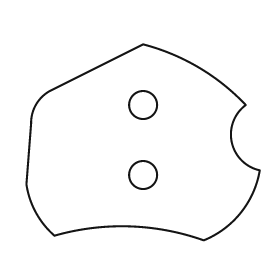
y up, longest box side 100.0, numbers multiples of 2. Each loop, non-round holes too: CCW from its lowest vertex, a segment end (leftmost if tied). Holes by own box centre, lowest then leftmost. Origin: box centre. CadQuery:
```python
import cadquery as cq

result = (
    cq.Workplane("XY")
    .moveTo(26.0, -42.0)
    .threePointArc((42.0, -30.0), (50.0, -12.0))
    .threePointArc((38.0, 0.0), (44.0, 16.0))
    .threePointArc((24.0, 32.0), (0.0, 42.0))
    .lineTo(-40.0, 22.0)
    .threePointArc((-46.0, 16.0), (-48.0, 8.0))
    .lineTo(-50.0, -18.0)
    .threePointArc((-46.0, -30.0), (-38.0, -40.0))
    .threePointArc((-6.0, -36.0), (26.0, -42.0))
    .close()
    .moveTo(0.0, -14.0)
    .circle(6.0)
    .moveTo(0.0, 16.0)
    .circle(6.0)
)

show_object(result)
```